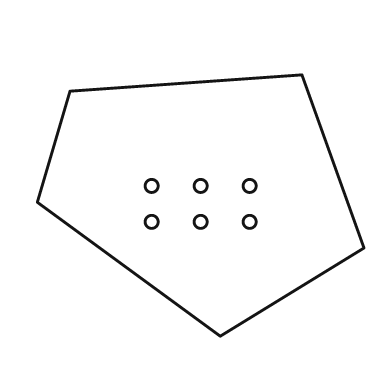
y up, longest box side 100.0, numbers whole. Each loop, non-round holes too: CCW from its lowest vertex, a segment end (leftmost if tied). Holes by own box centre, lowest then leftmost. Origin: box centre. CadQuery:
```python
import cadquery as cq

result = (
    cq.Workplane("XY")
    .moveTo(6.0, -40.0)
    .lineTo(50.0, -13.0)
    .lineTo(31.0, 40.0)
    .lineTo(-40.0, 35.0)
    .lineTo(-50.0, 1.0)
    .close()
    .moveTo(-15.0, -5.0)
    .circle(2.0)
    .moveTo(0.0, -5.0)
    .circle(2.0)
    .moveTo(15.0, -5.0)
    .circle(2.0)
    .moveTo(-15.0, 6.0)
    .circle(2.0)
    .moveTo(0.0, 6.0)
    .circle(2.0)
    .moveTo(15.0, 6.0)
    .circle(2.0)
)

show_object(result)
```